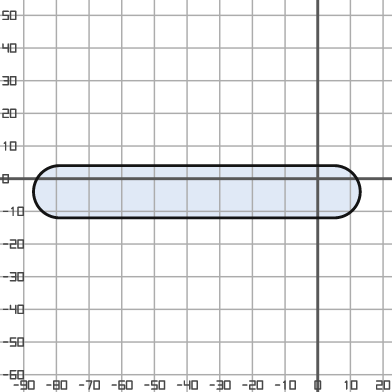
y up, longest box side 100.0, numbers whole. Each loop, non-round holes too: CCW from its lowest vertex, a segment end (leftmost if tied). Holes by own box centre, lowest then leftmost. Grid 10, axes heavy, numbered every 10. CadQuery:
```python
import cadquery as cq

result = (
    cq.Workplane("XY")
    .moveTo(-79.0, -12.0)
    .lineTo(5.0, -12.0)
    .threePointArc((13.0, -4.0), (5.0, 4.0))
    .lineTo(-79.0, 4.0)
    .threePointArc((-87.0, -4.0), (-79.0, -12.0))
    .close()
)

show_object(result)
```